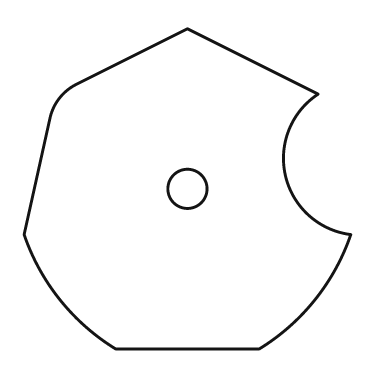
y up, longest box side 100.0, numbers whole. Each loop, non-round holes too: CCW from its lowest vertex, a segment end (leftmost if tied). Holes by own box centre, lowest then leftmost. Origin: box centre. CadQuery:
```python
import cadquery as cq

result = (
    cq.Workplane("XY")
    .moveTo(-22.0, -49.0)
    .lineTo(22.0, -49.0)
    .threePointArc((39.0, -34.0), (50.0, -14.0))
    .threePointArc((30.0, 4.0), (40.0, 29.0))
    .lineTo(0.0, 49.0)
    .lineTo(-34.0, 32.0)
    .threePointArc((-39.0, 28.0), (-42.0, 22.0))
    .lineTo(-50.0, -14.0)
    .threePointArc((-39.0, -34.0), (-22.0, -49.0))
    .close()
    .moveTo(0.0, 0.0)
    .circle(6.0)
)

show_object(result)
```